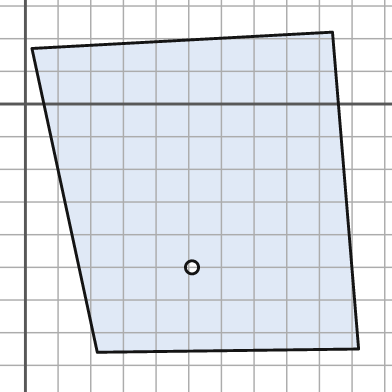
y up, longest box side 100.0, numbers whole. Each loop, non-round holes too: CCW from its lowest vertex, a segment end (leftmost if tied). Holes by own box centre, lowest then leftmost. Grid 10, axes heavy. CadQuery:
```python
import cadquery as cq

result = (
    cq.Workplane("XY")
    .moveTo(22.0, -76.0)
    .lineTo(102.0, -75.0)
    .lineTo(94.0, 22.0)
    .lineTo(2.0, 17.0)
    .close()
    .moveTo(51.0, -50.0)
    .circle(2.0)
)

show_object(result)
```